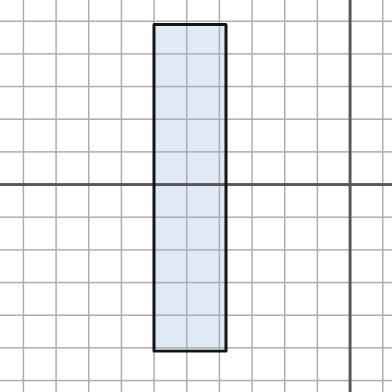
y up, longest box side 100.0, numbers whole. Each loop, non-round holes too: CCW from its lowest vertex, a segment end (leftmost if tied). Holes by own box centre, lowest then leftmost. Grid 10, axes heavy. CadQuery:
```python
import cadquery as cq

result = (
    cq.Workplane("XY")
    .moveTo(-60.0, -51.0)
    .lineTo(-38.0, -51.0)
    .lineTo(-38.0, 49.0)
    .lineTo(-60.0, 49.0)
    .close()
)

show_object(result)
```